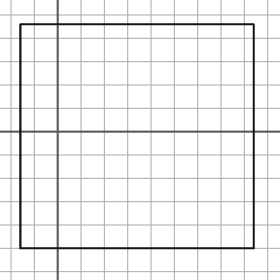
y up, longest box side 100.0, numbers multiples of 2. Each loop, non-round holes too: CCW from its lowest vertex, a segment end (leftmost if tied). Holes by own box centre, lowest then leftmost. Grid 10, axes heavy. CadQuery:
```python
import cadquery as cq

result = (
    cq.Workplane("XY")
    .moveTo(-16.0, -50.0)
    .lineTo(84.0, -50.0)
    .lineTo(84.0, 46.0)
    .lineTo(-16.0, 46.0)
    .close()
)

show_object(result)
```